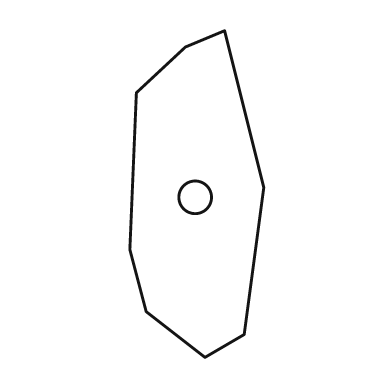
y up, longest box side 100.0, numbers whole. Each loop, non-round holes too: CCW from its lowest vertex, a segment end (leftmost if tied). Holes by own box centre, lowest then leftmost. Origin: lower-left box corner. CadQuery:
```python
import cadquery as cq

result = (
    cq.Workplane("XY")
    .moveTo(23.0, 0.0)
    .lineTo(35.0, 7.0)
    .lineTo(41.0, 52.0)
    .lineTo(29.0, 100.0)
    .lineTo(17.0, 95.0)
    .lineTo(2.0, 81.0)
    .lineTo(0.0, 33.0)
    .lineTo(5.0, 14.0)
    .close()
    .moveTo(20.0, 49.0)
    .circle(5.0)
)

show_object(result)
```